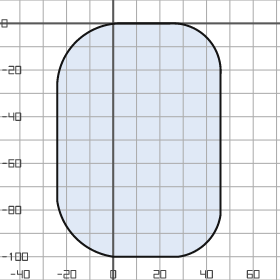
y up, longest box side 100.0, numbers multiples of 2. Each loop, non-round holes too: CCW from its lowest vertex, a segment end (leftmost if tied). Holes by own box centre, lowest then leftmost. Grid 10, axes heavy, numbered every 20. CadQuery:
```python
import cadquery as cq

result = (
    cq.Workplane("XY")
    .moveTo(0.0, -100.0)
    .lineTo(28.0, -100.0)
    .threePointArc((40.0, -94.0), (46.0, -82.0))
    .lineTo(46.0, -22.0)
    .threePointArc((40.0, -6.0), (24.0, 0.0))
    .lineTo(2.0, 0.0)
    .threePointArc((-16.0, -8.0), (-24.0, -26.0))
    .lineTo(-24.0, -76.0)
    .threePointArc((-16.0, -92.0), (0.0, -100.0))
    .close()
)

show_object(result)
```